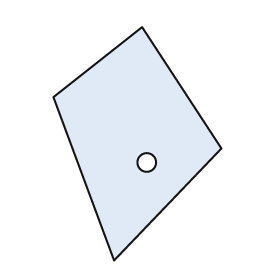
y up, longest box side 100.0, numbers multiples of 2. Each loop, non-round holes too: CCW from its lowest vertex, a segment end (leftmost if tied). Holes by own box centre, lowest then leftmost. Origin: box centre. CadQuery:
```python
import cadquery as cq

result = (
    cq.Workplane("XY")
    .moveTo(-10.0, -50.0)
    .lineTo(36.0, -2.0)
    .lineTo(2.0, 50.0)
    .lineTo(-36.0, 20.0)
    .close()
    .moveTo(4.0, -8.0)
    .circle(4.0)
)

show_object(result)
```